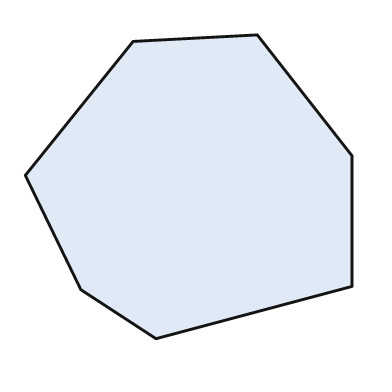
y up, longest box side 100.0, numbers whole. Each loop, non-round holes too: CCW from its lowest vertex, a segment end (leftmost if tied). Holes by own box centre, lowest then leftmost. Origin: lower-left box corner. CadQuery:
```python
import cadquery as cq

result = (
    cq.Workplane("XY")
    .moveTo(40.0, 0.0)
    .lineTo(100.0, 16.0)
    .lineTo(100.0, 56.0)
    .lineTo(71.0, 93.0)
    .lineTo(33.0, 91.0)
    .lineTo(0.0, 50.0)
    .lineTo(17.0, 15.0)
    .close()
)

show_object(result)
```